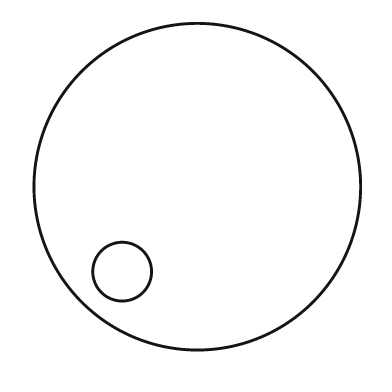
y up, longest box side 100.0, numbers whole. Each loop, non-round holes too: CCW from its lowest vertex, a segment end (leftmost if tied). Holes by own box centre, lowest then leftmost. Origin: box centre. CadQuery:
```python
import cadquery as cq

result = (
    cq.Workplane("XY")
    .moveTo(0.0, 0.0)
    .circle(50.0)
    .moveTo(-23.0, -26.0)
    .circle(9.0)
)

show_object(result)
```